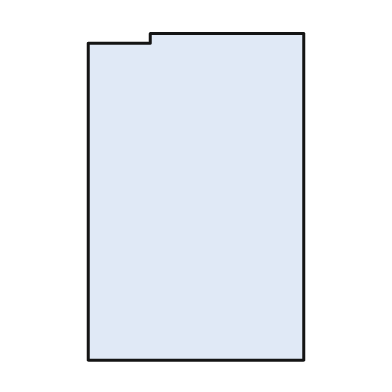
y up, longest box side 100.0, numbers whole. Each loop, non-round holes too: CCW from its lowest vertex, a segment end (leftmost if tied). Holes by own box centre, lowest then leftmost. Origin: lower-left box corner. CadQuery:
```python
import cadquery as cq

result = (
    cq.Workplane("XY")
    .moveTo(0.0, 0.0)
    .lineTo(66.0, 0.0)
    .lineTo(66.0, 100.0)
    .lineTo(19.0, 100.0)
    .lineTo(19.0, 97.0)
    .lineTo(0.0, 97.0)
    .close()
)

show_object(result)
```